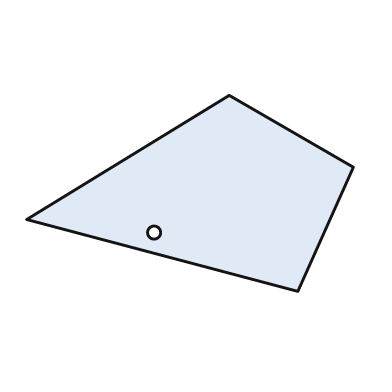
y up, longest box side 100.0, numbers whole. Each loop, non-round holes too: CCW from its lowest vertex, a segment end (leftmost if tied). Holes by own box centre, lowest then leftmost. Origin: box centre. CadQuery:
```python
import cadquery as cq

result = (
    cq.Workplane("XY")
    .moveTo(33.0, -30.0)
    .lineTo(50.0, 8.0)
    .lineTo(12.0, 30.0)
    .lineTo(-50.0, -8.0)
    .close()
    .moveTo(-11.0, -12.0)
    .circle(2.0)
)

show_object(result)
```